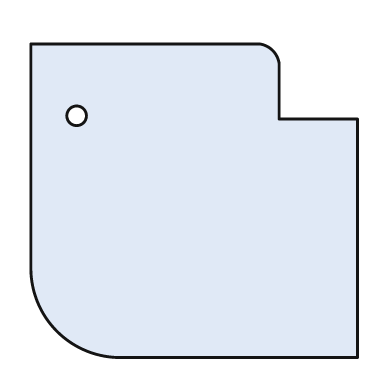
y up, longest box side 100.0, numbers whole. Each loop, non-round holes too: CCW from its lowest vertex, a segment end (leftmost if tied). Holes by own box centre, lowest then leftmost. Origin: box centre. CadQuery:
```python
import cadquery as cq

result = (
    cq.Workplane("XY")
    .moveTo(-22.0, -48.0)
    .lineTo(50.0, -48.0)
    .lineTo(50.0, 25.0)
    .lineTo(26.0, 25.0)
    .lineTo(26.0, 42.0)
    .threePointArc((24.0, 46.0), (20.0, 48.0))
    .lineTo(-50.0, 48.0)
    .lineTo(-50.0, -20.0)
    .threePointArc((-42.0, -40.0), (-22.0, -48.0))
    .close()
    .moveTo(-36.0, 26.0)
    .circle(3.0)
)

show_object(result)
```